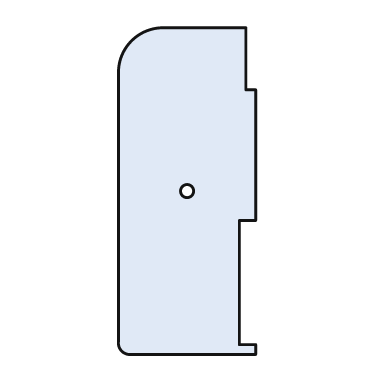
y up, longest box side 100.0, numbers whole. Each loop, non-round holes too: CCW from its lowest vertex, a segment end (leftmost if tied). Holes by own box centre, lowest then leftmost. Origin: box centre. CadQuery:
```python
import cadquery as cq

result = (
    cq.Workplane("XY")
    .moveTo(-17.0, -50.0)
    .lineTo(21.0, -50.0)
    .lineTo(21.0, -47.0)
    .lineTo(16.0, -47.0)
    .lineTo(16.0, -9.0)
    .lineTo(21.0, -9.0)
    .lineTo(21.0, 31.0)
    .lineTo(18.0, 31.0)
    .lineTo(18.0, 50.0)
    .lineTo(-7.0, 50.0)
    .threePointArc((-17.0, 46.0), (-21.0, 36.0))
    .lineTo(-21.0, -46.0)
    .threePointArc((-20.0, -49.0), (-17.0, -50.0))
    .close()
    .moveTo(0.0, 0.0)
    .circle(2.0)
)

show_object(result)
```